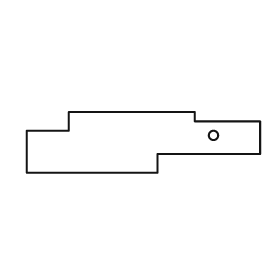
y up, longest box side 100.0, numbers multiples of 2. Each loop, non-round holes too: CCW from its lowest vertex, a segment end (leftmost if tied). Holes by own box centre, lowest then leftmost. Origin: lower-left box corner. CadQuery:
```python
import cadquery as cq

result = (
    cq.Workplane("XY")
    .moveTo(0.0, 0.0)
    .lineTo(56.0, 0.0)
    .lineTo(56.0, 8.0)
    .lineTo(100.0, 8.0)
    .lineTo(100.0, 22.0)
    .lineTo(72.0, 22.0)
    .lineTo(72.0, 26.0)
    .lineTo(18.0, 26.0)
    .lineTo(18.0, 18.0)
    .lineTo(0.0, 18.0)
    .close()
    .moveTo(80.0, 16.0)
    .circle(2.0)
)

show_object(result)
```